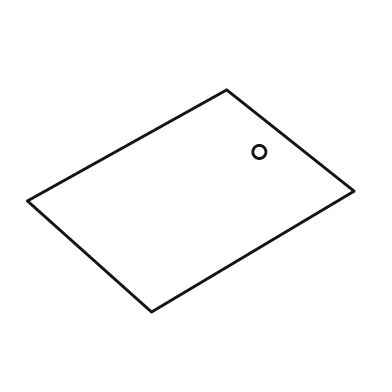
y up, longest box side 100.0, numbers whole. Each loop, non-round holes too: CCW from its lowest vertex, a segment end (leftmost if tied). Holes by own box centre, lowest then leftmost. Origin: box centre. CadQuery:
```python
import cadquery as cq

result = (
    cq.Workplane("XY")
    .moveTo(-12.0, -34.0)
    .lineTo(50.0, 3.0)
    .lineTo(11.0, 34.0)
    .lineTo(-50.0, 0.0)
    .close()
    .moveTo(21.0, 15.0)
    .circle(2.0)
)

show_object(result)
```